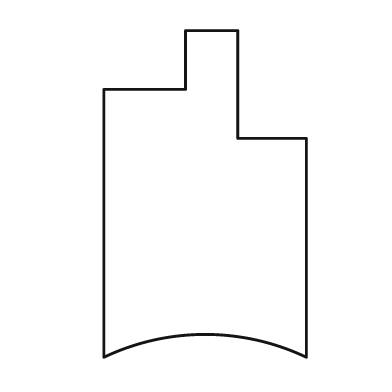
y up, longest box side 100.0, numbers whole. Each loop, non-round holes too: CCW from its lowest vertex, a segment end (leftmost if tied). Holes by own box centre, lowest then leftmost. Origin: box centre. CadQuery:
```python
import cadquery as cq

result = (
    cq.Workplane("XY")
    .moveTo(-31.0, -50.0)
    .threePointArc((0.0, -43.0), (31.0, -50.0))
    .lineTo(31.0, 17.0)
    .lineTo(10.0, 17.0)
    .lineTo(10.0, 50.0)
    .lineTo(-6.0, 50.0)
    .lineTo(-6.0, 32.0)
    .lineTo(-31.0, 32.0)
    .close()
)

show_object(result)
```